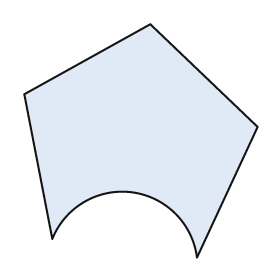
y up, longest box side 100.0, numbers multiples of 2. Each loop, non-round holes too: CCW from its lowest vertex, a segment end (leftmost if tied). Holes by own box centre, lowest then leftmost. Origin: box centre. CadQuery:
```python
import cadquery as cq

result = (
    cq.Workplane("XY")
    .moveTo(24.0, -50.0)
    .lineTo(50.0, 6.0)
    .lineTo(4.0, 50.0)
    .lineTo(-50.0, 20.0)
    .lineTo(-38.0, -42.0)
    .threePointArc((-4.0, -22.0), (24.0, -50.0))
    .close()
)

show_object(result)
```